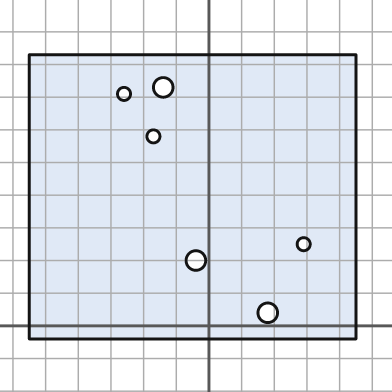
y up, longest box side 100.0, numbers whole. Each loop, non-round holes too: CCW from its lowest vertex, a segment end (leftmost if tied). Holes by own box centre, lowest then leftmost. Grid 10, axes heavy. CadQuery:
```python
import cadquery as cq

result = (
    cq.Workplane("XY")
    .moveTo(-55.0, -4.0)
    .lineTo(45.0, -4.0)
    .lineTo(45.0, 83.0)
    .lineTo(-55.0, 83.0)
    .close()
    .moveTo(18.0, 4.0)
    .circle(3.0)
    .moveTo(-4.0, 20.0)
    .circle(3.0)
    .moveTo(29.0, 25.0)
    .circle(2.0)
    .moveTo(-17.0, 58.0)
    .circle(2.0)
    .moveTo(-26.0, 71.0)
    .circle(2.0)
    .moveTo(-14.0, 73.0)
    .circle(3.0)
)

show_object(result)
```